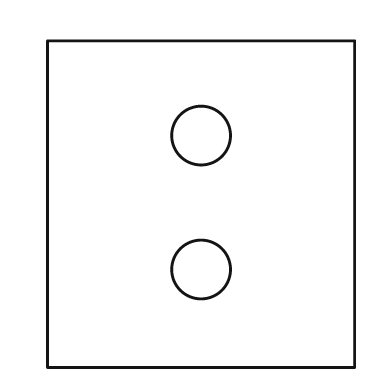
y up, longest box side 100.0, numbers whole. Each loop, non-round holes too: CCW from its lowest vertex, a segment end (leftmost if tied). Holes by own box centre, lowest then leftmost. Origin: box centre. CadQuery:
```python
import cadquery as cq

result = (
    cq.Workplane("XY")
    .moveTo(-47.0, -50.0)
    .lineTo(47.0, -50.0)
    .lineTo(47.0, 50.0)
    .lineTo(-47.0, 50.0)
    .close()
    .moveTo(0.0, -20.0)
    .circle(9.0)
    .moveTo(0.0, 21.0)
    .circle(9.0)
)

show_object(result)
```